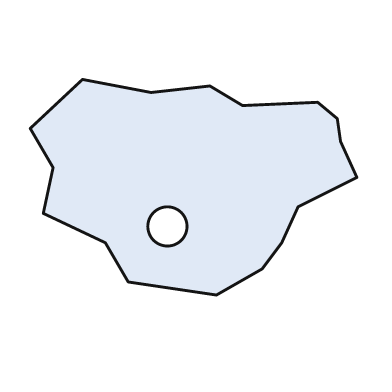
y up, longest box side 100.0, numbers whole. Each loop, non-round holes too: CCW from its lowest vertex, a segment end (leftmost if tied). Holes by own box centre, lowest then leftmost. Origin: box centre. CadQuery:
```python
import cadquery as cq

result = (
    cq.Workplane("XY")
    .moveTo(7.0, -33.0)
    .lineTo(21.0, -25.0)
    .lineTo(27.0, -17.0)
    .lineTo(32.0, -6.0)
    .lineTo(50.0, 3.0)
    .lineTo(45.0, 14.0)
    .lineTo(44.0, 21.0)
    .lineTo(38.0, 26.0)
    .lineTo(15.0, 25.0)
    .lineTo(5.0, 31.0)
    .lineTo(-13.0, 29.0)
    .lineTo(-34.0, 33.0)
    .lineTo(-50.0, 18.0)
    .lineTo(-43.0, 6.0)
    .lineTo(-46.0, -8.0)
    .lineTo(-27.0, -17.0)
    .lineTo(-20.0, -29.0)
    .close()
    .moveTo(-8.0, -12.0)
    .circle(6.0)
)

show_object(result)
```